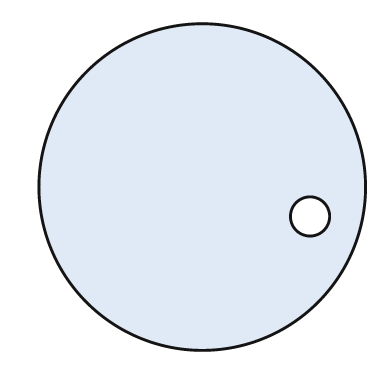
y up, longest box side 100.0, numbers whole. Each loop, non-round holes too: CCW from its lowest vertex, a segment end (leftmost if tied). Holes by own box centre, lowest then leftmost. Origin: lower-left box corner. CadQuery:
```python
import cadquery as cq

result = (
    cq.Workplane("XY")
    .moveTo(50.0, 50.0)
    .circle(50.0)
    .moveTo(83.0, 41.0)
    .circle(6.0)
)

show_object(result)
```